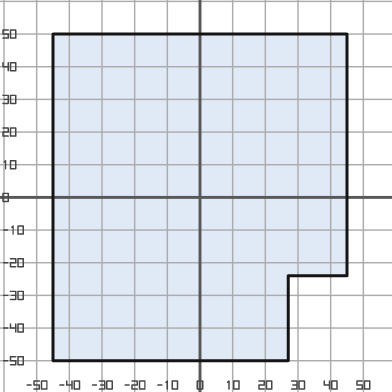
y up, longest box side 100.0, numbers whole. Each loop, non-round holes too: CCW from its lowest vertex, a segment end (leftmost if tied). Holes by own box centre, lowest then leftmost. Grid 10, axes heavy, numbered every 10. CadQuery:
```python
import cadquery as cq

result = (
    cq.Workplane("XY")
    .moveTo(-45.0, -50.0)
    .lineTo(27.0, -50.0)
    .lineTo(27.0, -24.0)
    .lineTo(45.0, -24.0)
    .lineTo(45.0, 50.0)
    .lineTo(-45.0, 50.0)
    .close()
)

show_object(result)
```